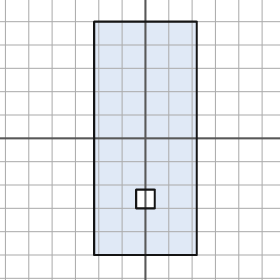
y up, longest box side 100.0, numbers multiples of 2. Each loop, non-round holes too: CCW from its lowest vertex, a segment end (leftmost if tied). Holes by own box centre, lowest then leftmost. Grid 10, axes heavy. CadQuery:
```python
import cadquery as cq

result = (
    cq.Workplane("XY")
    .moveTo(-22.0, -50.0)
    .lineTo(22.0, -50.0)
    .lineTo(22.0, 50.0)
    .lineTo(-22.0, 50.0)
    .close()
    .moveTo(-4.0, -30.0)
    .lineTo(4.0, -30.0)
    .lineTo(4.0, -22.0)
    .lineTo(-4.0, -22.0)
    .close()
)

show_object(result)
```